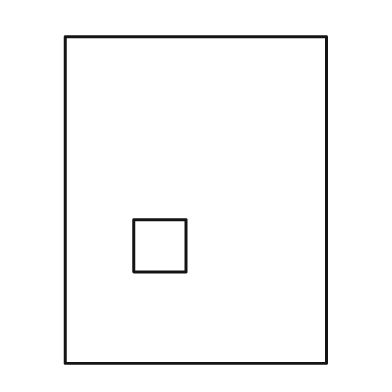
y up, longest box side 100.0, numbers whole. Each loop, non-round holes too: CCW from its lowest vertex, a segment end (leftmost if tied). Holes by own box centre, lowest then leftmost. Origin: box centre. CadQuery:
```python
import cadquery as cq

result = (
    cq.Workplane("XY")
    .moveTo(-40.0, -50.0)
    .lineTo(40.0, -50.0)
    .lineTo(40.0, 50.0)
    .lineTo(-40.0, 50.0)
    .close()
    .moveTo(-19.0, -22.0)
    .lineTo(-3.0, -22.0)
    .lineTo(-3.0, -6.0)
    .lineTo(-19.0, -6.0)
    .close()
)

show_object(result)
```